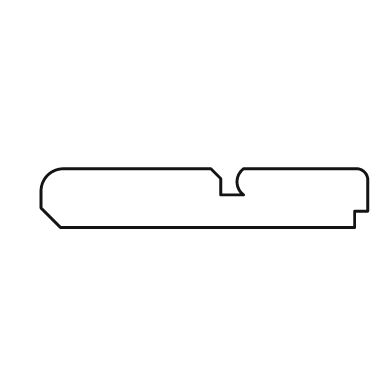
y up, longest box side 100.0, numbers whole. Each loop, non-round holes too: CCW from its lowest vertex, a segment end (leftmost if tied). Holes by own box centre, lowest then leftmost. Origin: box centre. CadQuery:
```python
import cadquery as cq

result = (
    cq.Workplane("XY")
    .moveTo(-44.0, -9.0)
    .lineTo(46.0, -9.0)
    .lineTo(46.0, -4.0)
    .lineTo(50.0, -4.0)
    .lineTo(50.0, 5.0)
    .threePointArc((49.0, 8.0), (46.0, 9.0))
    .lineTo(12.0, 9.0)
    .threePointArc((10.0, 5.0), (12.0, 1.0))
    .lineTo(5.0, 1.0)
    .lineTo(5.0, 6.0)
    .lineTo(2.0, 9.0)
    .lineTo(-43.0, 9.0)
    .threePointArc((-48.0, 7.0), (-50.0, 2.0))
    .lineTo(-50.0, -3.0)
    .close()
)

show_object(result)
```